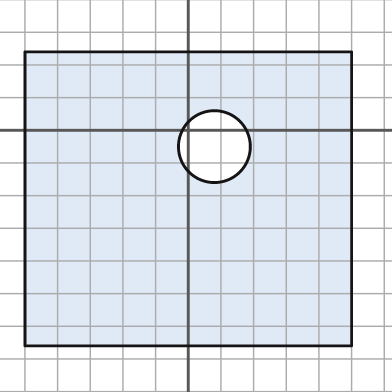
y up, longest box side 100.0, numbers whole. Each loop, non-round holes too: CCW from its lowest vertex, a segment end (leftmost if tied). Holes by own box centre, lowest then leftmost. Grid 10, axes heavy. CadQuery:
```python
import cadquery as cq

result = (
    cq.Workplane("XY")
    .moveTo(-50.0, -66.0)
    .lineTo(50.0, -66.0)
    .lineTo(50.0, 24.0)
    .lineTo(-50.0, 24.0)
    .close()
    .moveTo(8.0, -5.0)
    .circle(11.0)
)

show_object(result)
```